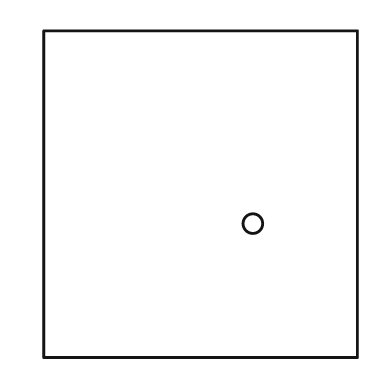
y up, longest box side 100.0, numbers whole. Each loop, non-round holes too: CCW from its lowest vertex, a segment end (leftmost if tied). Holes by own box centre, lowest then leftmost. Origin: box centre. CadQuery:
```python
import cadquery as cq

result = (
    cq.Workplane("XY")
    .moveTo(-48.0, -50.0)
    .lineTo(48.0, -50.0)
    .lineTo(48.0, 50.0)
    .lineTo(-48.0, 50.0)
    .close()
    .moveTo(16.0, -9.0)
    .circle(3.0)
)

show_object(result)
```